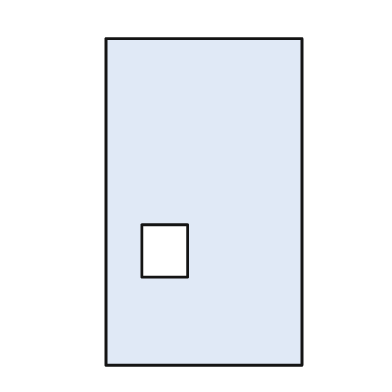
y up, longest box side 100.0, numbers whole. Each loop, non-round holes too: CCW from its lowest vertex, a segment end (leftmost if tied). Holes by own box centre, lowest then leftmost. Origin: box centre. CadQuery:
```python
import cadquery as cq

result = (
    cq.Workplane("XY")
    .moveTo(-30.0, -50.0)
    .lineTo(30.0, -50.0)
    .lineTo(30.0, 50.0)
    .lineTo(-30.0, 50.0)
    .close()
    .moveTo(-19.0, -23.0)
    .lineTo(-5.0, -23.0)
    .lineTo(-5.0, -7.0)
    .lineTo(-19.0, -7.0)
    .close()
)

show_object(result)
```